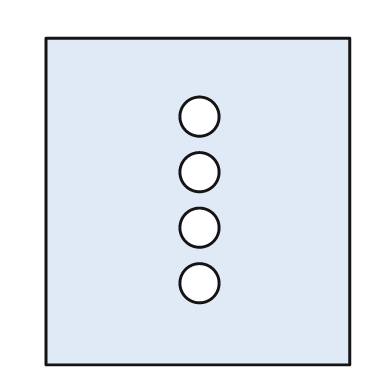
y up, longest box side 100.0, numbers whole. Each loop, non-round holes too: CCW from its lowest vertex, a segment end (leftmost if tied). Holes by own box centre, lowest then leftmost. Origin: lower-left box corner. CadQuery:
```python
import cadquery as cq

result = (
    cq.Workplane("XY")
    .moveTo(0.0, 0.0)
    .lineTo(93.0, 0.0)
    .lineTo(93.0, 100.0)
    .lineTo(0.0, 100.0)
    .close()
    .moveTo(47.0, 25.0)
    .circle(6.0)
    .moveTo(47.0, 42.0)
    .circle(6.0)
    .moveTo(47.0, 59.0)
    .circle(6.0)
    .moveTo(47.0, 76.0)
    .circle(6.0)
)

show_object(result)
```